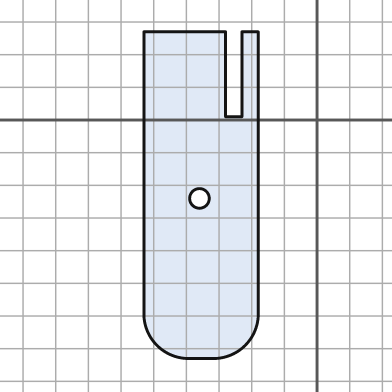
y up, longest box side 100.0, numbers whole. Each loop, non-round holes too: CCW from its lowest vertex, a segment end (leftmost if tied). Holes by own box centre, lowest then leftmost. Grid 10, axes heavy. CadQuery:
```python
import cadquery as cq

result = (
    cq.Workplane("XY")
    .moveTo(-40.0, -73.0)
    .lineTo(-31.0, -73.0)
    .threePointArc((-22.0, -69.0), (-18.0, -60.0))
    .lineTo(-18.0, 27.0)
    .lineTo(-23.0, 27.0)
    .lineTo(-23.0, 1.0)
    .lineTo(-28.0, 1.0)
    .lineTo(-28.0, 27.0)
    .lineTo(-53.0, 27.0)
    .lineTo(-53.0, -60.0)
    .threePointArc((-49.0, -69.0), (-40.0, -73.0))
    .close()
    .moveTo(-36.0, -24.0)
    .circle(3.0)
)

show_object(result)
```